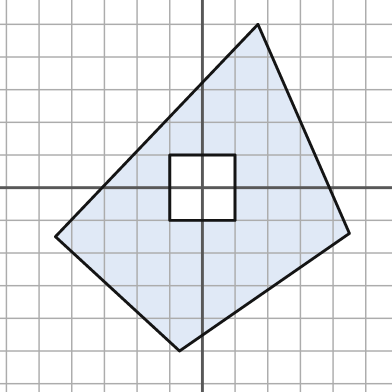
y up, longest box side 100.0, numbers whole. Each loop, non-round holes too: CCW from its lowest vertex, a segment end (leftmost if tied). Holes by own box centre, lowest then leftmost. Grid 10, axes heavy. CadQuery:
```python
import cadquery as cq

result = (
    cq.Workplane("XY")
    .moveTo(-7.0, -50.0)
    .lineTo(45.0, -14.0)
    .lineTo(17.0, 50.0)
    .lineTo(-45.0, -15.0)
    .close()
    .moveTo(-10.0, -10.0)
    .lineTo(10.0, -10.0)
    .lineTo(10.0, 10.0)
    .lineTo(-10.0, 10.0)
    .close()
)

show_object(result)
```